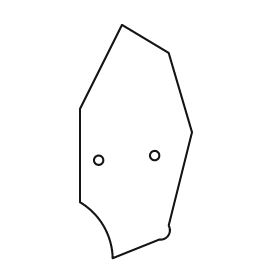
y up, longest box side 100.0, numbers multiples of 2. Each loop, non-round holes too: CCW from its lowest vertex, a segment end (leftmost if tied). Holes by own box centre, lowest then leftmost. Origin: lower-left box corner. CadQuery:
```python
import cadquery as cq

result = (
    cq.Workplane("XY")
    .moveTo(14.0, 0.0)
    .lineTo(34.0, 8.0)
    .threePointArc((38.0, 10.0), (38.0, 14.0))
    .lineTo(48.0, 54.0)
    .lineTo(38.0, 88.0)
    .lineTo(18.0, 100.0)
    .lineTo(0.0, 64.0)
    .lineTo(0.0, 24.0)
    .threePointArc((10.0, 14.0), (14.0, 0.0))
    .close()
    .moveTo(8.0, 42.0)
    .circle(2.0)
    .moveTo(32.0, 44.0)
    .circle(2.0)
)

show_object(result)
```